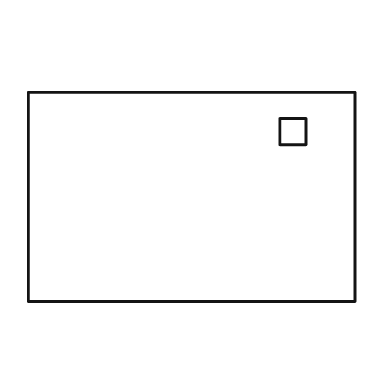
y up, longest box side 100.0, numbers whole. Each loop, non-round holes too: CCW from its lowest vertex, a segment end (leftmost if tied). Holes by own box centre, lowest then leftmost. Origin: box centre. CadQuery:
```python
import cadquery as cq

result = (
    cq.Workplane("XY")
    .moveTo(-50.0, -32.0)
    .lineTo(50.0, -32.0)
    .lineTo(50.0, 32.0)
    .lineTo(-50.0, 32.0)
    .close()
    .moveTo(27.0, 16.0)
    .lineTo(35.0, 16.0)
    .lineTo(35.0, 24.0)
    .lineTo(27.0, 24.0)
    .close()
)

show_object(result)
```